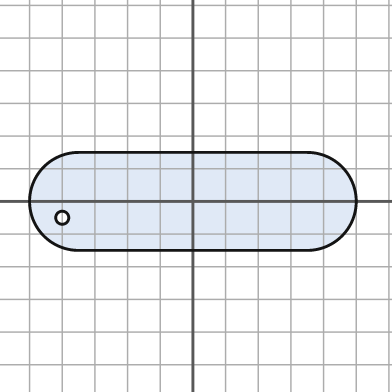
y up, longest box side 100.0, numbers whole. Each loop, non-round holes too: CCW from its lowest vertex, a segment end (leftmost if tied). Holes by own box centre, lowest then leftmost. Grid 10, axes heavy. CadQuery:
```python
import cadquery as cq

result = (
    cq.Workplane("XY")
    .moveTo(-35.0, -15.0)
    .lineTo(35.0, -15.0)
    .threePointArc((50.0, 0.0), (35.0, 15.0))
    .lineTo(-35.0, 15.0)
    .threePointArc((-50.0, 0.0), (-35.0, -15.0))
    .close()
    .moveTo(-40.0, -5.0)
    .circle(2.0)
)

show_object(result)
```